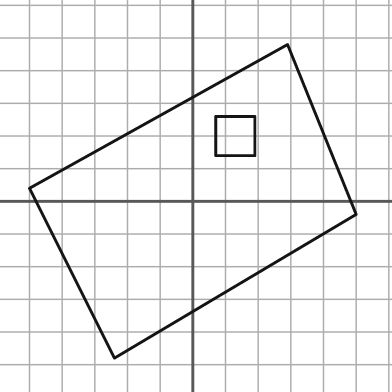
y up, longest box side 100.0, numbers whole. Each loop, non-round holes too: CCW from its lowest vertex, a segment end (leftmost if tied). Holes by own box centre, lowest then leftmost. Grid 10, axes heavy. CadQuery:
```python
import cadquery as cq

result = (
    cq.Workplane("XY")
    .moveTo(-24.0, -48.0)
    .lineTo(50.0, -4.0)
    .lineTo(29.0, 48.0)
    .lineTo(-50.0, 4.0)
    .close()
    .moveTo(7.0, 14.0)
    .lineTo(19.0, 14.0)
    .lineTo(19.0, 26.0)
    .lineTo(7.0, 26.0)
    .close()
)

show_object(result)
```